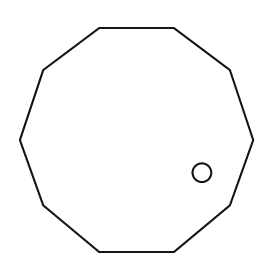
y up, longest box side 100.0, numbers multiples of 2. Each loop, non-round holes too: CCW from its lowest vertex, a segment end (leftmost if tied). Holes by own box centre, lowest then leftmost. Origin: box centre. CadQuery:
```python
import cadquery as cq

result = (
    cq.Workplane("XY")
    .moveTo(-16.0, -48.0)
    .lineTo(16.0, -48.0)
    .lineTo(40.0, -28.0)
    .lineTo(50.0, 0.0)
    .lineTo(40.0, 30.0)
    .lineTo(16.0, 48.0)
    .lineTo(-16.0, 48.0)
    .lineTo(-40.0, 30.0)
    .lineTo(-50.0, 0.0)
    .lineTo(-40.0, -28.0)
    .close()
    .moveTo(28.0, -14.0)
    .circle(4.0)
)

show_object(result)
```